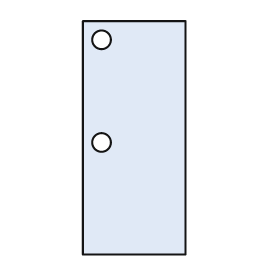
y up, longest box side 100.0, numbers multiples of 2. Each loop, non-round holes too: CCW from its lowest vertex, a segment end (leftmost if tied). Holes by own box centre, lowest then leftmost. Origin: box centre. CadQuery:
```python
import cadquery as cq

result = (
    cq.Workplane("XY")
    .moveTo(-22.0, -50.0)
    .lineTo(22.0, -50.0)
    .lineTo(22.0, 50.0)
    .lineTo(-22.0, 50.0)
    .close()
    .moveTo(-14.0, -2.0)
    .circle(4.0)
    .moveTo(-14.0, 42.0)
    .circle(4.0)
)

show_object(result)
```